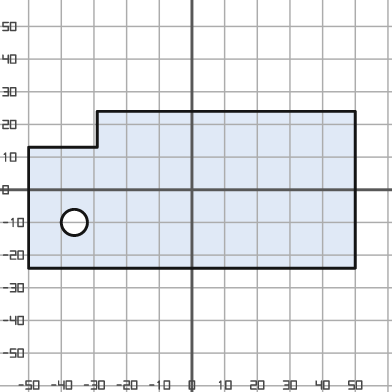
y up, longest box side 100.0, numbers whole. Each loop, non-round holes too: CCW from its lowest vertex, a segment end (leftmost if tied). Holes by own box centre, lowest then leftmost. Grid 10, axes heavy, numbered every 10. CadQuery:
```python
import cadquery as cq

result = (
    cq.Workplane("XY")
    .moveTo(-50.0, -24.0)
    .lineTo(50.0, -24.0)
    .lineTo(50.0, 24.0)
    .lineTo(-29.0, 24.0)
    .lineTo(-29.0, 13.0)
    .lineTo(-50.0, 13.0)
    .close()
    .moveTo(-36.0, -10.0)
    .circle(4.0)
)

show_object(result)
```